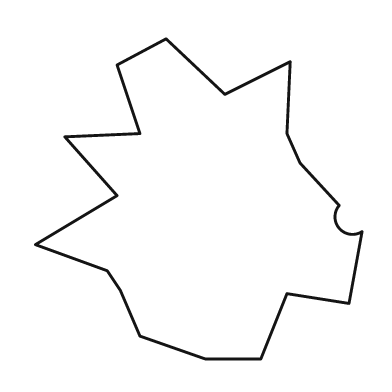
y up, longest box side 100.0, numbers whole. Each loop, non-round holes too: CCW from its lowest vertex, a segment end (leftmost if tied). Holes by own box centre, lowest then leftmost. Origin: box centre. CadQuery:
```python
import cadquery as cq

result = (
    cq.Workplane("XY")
    .moveTo(2.0, -49.0)
    .lineTo(19.0, -49.0)
    .lineTo(27.0, -29.0)
    .lineTo(46.0, -32.0)
    .lineTo(50.0, -10.0)
    .threePointArc((43.0, -9.0), (43.0, -2.0))
    .lineTo(31.0, 11.0)
    .lineTo(27.0, 20.0)
    .lineTo(28.0, 42.0)
    .lineTo(8.0, 32.0)
    .lineTo(-10.0, 49.0)
    .lineTo(-25.0, 41.0)
    .lineTo(-18.0, 20.0)
    .lineTo(-41.0, 19.0)
    .lineTo(-25.0, 1.0)
    .lineTo(-50.0, -14.0)
    .lineTo(-28.0, -22.0)
    .lineTo(-24.0, -28.0)
    .lineTo(-18.0, -42.0)
    .close()
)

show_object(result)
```